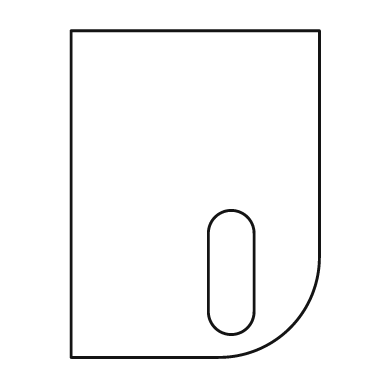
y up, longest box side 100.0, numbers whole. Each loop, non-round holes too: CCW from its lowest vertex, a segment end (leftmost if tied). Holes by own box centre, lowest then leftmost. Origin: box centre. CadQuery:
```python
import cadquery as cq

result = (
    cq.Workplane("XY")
    .moveTo(-38.0, -50.0)
    .lineTo(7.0, -50.0)
    .threePointArc((29.0, -41.0), (38.0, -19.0))
    .lineTo(38.0, 50.0)
    .lineTo(-38.0, 50.0)
    .close()
    .moveTo(4.0, -36.0)
    .threePointArc((11.0, -43.0), (18.0, -36.0))
    .lineTo(18.0, -12.0)
    .threePointArc((11.0, -5.0), (4.0, -12.0))
    .close()
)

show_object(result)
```